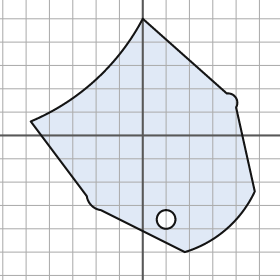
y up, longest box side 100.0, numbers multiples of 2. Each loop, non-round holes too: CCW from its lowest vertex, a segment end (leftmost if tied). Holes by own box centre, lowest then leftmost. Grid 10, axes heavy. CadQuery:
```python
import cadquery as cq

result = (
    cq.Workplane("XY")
    .moveTo(18.0, -50.0)
    .threePointArc((36.0, -40.0), (48.0, -24.0))
    .lineTo(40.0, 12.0)
    .threePointArc((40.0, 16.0), (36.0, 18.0))
    .lineTo(0.0, 50.0)
    .threePointArc((-20.0, 24.0), (-48.0, 6.0))
    .lineTo(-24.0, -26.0)
    .threePointArc((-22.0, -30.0), (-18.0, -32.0))
    .close()
    .moveTo(10.0, -36.0)
    .circle(4.0)
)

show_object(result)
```